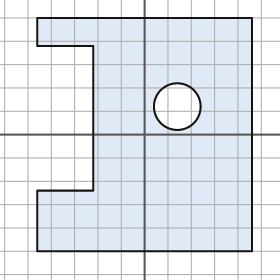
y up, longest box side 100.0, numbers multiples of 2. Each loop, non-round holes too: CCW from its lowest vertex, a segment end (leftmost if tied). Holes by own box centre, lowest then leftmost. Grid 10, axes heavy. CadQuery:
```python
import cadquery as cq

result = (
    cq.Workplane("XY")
    .moveTo(-46.0, -50.0)
    .lineTo(46.0, -50.0)
    .lineTo(46.0, 50.0)
    .lineTo(-46.0, 50.0)
    .lineTo(-46.0, 38.0)
    .lineTo(-22.0, 38.0)
    .lineTo(-22.0, -24.0)
    .lineTo(-46.0, -24.0)
    .close()
    .moveTo(14.0, 12.0)
    .circle(10.0)
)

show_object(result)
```